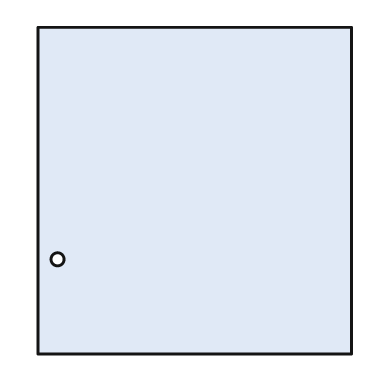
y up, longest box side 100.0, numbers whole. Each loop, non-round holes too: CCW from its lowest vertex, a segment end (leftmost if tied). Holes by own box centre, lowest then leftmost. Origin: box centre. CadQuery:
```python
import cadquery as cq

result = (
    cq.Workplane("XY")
    .moveTo(-48.0, -50.0)
    .lineTo(48.0, -50.0)
    .lineTo(48.0, 50.0)
    .lineTo(-48.0, 50.0)
    .close()
    .moveTo(-42.0, -21.0)
    .circle(2.0)
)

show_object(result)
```